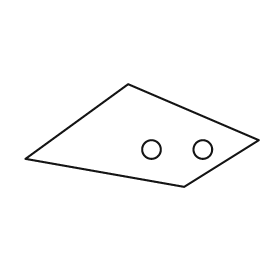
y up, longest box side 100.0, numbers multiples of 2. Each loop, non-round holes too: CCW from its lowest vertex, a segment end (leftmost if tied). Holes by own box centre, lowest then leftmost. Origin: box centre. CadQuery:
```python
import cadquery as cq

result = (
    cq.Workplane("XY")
    .moveTo(18.0, -22.0)
    .lineTo(50.0, -2.0)
    .lineTo(-6.0, 22.0)
    .lineTo(-50.0, -10.0)
    .close()
    .moveTo(4.0, -6.0)
    .circle(4.0)
    .moveTo(26.0, -6.0)
    .circle(4.0)
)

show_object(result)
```